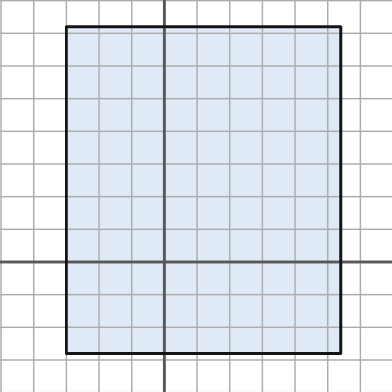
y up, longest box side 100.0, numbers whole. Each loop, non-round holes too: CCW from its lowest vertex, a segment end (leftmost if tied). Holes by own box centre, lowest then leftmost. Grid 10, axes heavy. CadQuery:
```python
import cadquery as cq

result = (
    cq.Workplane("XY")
    .moveTo(-30.0, -28.0)
    .lineTo(54.0, -28.0)
    .lineTo(54.0, 72.0)
    .lineTo(-30.0, 72.0)
    .close()
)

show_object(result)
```